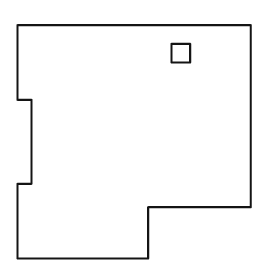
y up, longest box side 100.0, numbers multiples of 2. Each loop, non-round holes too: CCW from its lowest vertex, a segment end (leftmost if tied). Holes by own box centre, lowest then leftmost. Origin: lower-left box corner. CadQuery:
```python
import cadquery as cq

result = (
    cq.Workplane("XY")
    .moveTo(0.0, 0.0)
    .lineTo(56.0, 0.0)
    .lineTo(56.0, 22.0)
    .lineTo(100.0, 22.0)
    .lineTo(100.0, 100.0)
    .lineTo(0.0, 100.0)
    .lineTo(0.0, 68.0)
    .lineTo(6.0, 68.0)
    .lineTo(6.0, 32.0)
    .lineTo(0.0, 32.0)
    .close()
    .moveTo(66.0, 84.0)
    .lineTo(74.0, 84.0)
    .lineTo(74.0, 92.0)
    .lineTo(66.0, 92.0)
    .close()
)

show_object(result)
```